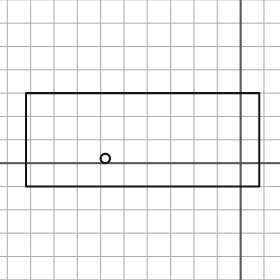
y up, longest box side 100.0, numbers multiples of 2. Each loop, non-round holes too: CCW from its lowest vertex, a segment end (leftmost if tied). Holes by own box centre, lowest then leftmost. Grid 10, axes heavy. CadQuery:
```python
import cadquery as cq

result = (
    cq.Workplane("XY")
    .moveTo(-92.0, -10.0)
    .lineTo(8.0, -10.0)
    .lineTo(8.0, 30.0)
    .lineTo(-92.0, 30.0)
    .close()
    .moveTo(-58.0, 2.0)
    .circle(2.0)
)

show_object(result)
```